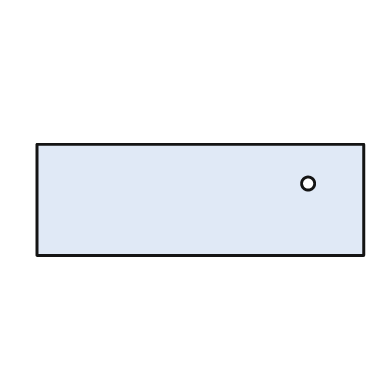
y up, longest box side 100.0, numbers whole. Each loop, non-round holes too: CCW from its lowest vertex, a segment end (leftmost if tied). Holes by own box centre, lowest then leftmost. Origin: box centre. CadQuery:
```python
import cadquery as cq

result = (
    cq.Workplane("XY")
    .moveTo(-50.0, -17.0)
    .lineTo(50.0, -17.0)
    .lineTo(50.0, 17.0)
    .lineTo(-50.0, 17.0)
    .close()
    .moveTo(33.0, 5.0)
    .circle(2.0)
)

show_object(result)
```